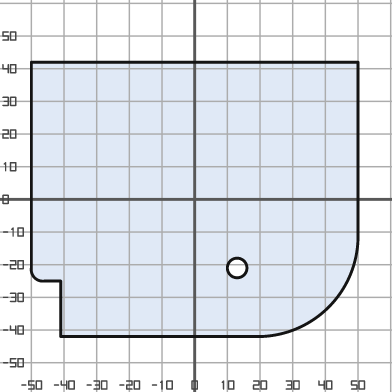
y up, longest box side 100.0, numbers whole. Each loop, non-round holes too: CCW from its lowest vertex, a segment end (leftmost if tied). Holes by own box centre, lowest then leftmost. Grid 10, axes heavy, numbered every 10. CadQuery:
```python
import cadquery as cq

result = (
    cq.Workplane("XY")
    .moveTo(-41.0, -42.0)
    .lineTo(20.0, -42.0)
    .threePointArc((41.0, -33.0), (50.0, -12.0))
    .lineTo(50.0, 42.0)
    .lineTo(-50.0, 42.0)
    .lineTo(-50.0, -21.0)
    .threePointArc((-49.0, -24.0), (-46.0, -25.0))
    .lineTo(-41.0, -25.0)
    .close()
    .moveTo(13.0, -21.0)
    .circle(3.0)
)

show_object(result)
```